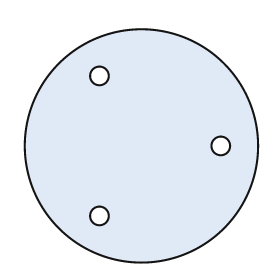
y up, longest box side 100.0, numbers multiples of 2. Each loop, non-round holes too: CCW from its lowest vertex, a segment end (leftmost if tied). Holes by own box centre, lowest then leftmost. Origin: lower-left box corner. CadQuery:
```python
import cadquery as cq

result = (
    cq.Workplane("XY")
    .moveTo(50.0, 50.0)
    .circle(50.0)
    .moveTo(32.0, 20.0)
    .circle(4.0)
    .moveTo(84.0, 50.0)
    .circle(4.0)
    .moveTo(32.0, 80.0)
    .circle(4.0)
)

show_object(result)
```